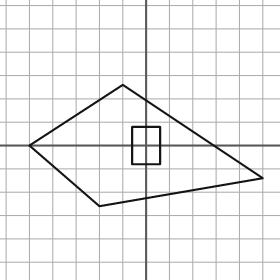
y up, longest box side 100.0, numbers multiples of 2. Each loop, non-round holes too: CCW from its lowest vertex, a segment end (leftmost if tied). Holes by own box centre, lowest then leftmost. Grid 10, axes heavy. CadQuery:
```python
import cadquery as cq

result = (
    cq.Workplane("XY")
    .moveTo(-20.0, -26.0)
    .lineTo(50.0, -14.0)
    .lineTo(-10.0, 26.0)
    .lineTo(-50.0, 0.0)
    .close()
    .moveTo(-6.0, -8.0)
    .lineTo(6.0, -8.0)
    .lineTo(6.0, 8.0)
    .lineTo(-6.0, 8.0)
    .close()
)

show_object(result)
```